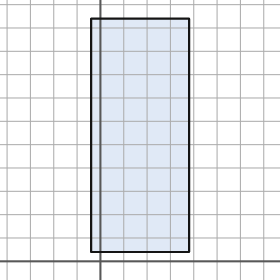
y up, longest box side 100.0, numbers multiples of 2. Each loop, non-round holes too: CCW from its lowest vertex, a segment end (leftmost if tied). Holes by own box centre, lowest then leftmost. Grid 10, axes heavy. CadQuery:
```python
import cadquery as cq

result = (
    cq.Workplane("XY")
    .moveTo(-4.0, 4.0)
    .lineTo(38.0, 4.0)
    .lineTo(38.0, 104.0)
    .lineTo(-4.0, 104.0)
    .close()
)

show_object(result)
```